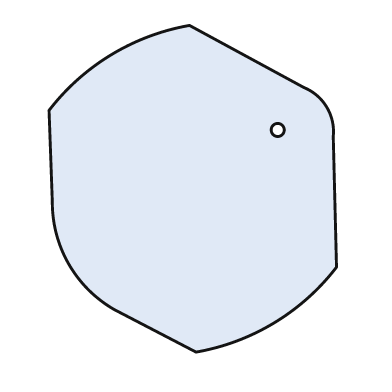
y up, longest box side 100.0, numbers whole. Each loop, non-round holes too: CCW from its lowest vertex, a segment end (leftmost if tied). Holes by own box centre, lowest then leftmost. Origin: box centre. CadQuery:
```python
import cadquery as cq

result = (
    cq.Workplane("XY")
    .moveTo(1.0, -50.0)
    .threePointArc((25.0, -41.0), (44.0, -24.0))
    .lineTo(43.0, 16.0)
    .threePointArc((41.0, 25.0), (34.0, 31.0))
    .lineTo(-1.0, 50.0)
    .threePointArc((-25.0, 41.0), (-44.0, 24.0))
    .lineTo(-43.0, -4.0)
    .threePointArc((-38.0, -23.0), (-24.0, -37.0))
    .close()
    .moveTo(26.0, 18.0)
    .circle(2.0)
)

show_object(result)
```